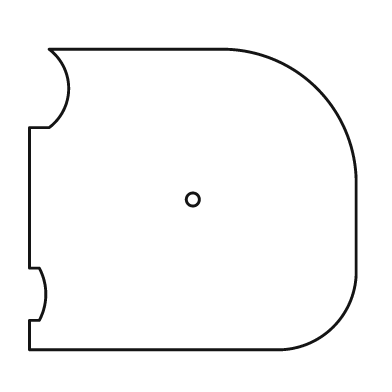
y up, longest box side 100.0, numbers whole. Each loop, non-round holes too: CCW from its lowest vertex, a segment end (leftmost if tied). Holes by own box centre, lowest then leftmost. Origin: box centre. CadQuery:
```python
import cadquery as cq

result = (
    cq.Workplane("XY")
    .moveTo(-50.0, -46.0)
    .lineTo(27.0, -46.0)
    .threePointArc((43.0, -39.0), (50.0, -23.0))
    .lineTo(50.0, 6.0)
    .threePointArc((38.0, 34.0), (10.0, 46.0))
    .lineTo(-44.0, 46.0)
    .threePointArc((-38.0, 34.0), (-44.0, 22.0))
    .lineTo(-50.0, 22.0)
    .lineTo(-50.0, -21.0)
    .lineTo(-47.0, -21.0)
    .threePointArc((-45.0, -29.0), (-47.0, -37.0))
    .lineTo(-50.0, -37.0)
    .close()
    .moveTo(0.0, 0.0)
    .circle(2.0)
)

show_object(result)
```